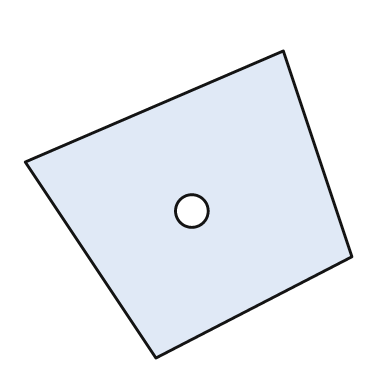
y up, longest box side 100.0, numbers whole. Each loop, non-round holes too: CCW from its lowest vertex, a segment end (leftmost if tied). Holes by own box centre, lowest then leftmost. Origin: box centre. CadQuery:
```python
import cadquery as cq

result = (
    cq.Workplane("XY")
    .moveTo(-10.0, -47.0)
    .lineTo(50.0, -16.0)
    .lineTo(29.0, 47.0)
    .lineTo(-50.0, 13.0)
    .close()
    .moveTo(1.0, -2.0)
    .circle(5.0)
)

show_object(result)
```